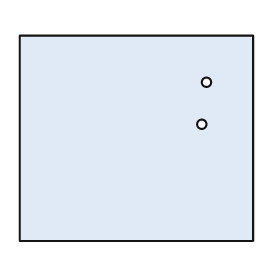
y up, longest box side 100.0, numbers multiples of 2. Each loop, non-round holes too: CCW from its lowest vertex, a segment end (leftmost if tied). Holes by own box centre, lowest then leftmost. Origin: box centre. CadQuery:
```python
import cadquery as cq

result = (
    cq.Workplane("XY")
    .moveTo(-50.0, -44.0)
    .lineTo(50.0, -44.0)
    .lineTo(50.0, 44.0)
    .lineTo(-50.0, 44.0)
    .close()
    .moveTo(28.0, 6.0)
    .circle(2.0)
    .moveTo(30.0, 24.0)
    .circle(2.0)
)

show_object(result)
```